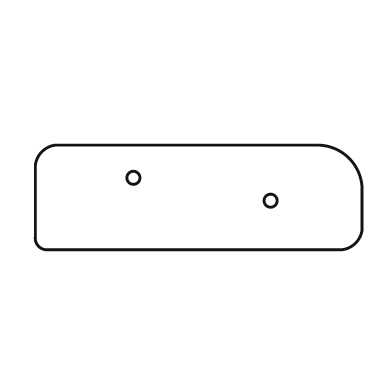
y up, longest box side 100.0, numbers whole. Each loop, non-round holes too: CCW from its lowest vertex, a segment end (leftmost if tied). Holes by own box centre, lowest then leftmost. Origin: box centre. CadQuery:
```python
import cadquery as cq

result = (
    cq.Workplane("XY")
    .moveTo(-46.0, -16.0)
    .lineTo(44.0, -16.0)
    .threePointArc((48.0, -14.0), (50.0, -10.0))
    .lineTo(50.0, 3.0)
    .threePointArc((46.0, 12.0), (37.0, 16.0))
    .lineTo(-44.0, 16.0)
    .threePointArc((-48.0, 14.0), (-50.0, 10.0))
    .lineTo(-50.0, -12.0)
    .threePointArc((-49.0, -15.0), (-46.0, -16.0))
    .close()
    .moveTo(22.0, -1.0)
    .circle(2.0)
    .moveTo(-20.0, 6.0)
    .circle(2.0)
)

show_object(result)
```